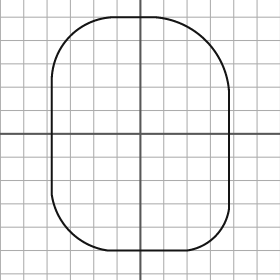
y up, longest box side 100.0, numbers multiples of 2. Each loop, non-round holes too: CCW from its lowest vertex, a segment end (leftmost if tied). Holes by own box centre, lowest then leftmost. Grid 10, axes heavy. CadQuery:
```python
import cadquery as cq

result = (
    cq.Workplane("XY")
    .moveTo(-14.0, -50.0)
    .lineTo(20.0, -50.0)
    .threePointArc((32.0, -44.0), (38.0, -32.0))
    .lineTo(38.0, 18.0)
    .threePointArc((28.0, 40.0), (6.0, 50.0))
    .lineTo(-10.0, 50.0)
    .threePointArc((-30.0, 42.0), (-38.0, 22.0))
    .lineTo(-38.0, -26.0)
    .threePointArc((-30.0, -42.0), (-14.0, -50.0))
    .close()
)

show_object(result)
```